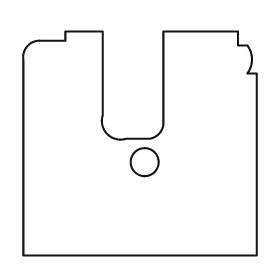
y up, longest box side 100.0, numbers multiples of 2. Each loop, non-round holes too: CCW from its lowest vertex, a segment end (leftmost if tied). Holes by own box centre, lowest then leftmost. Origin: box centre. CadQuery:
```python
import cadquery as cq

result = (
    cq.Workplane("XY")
    .moveTo(-50.0, -48.0)
    .lineTo(50.0, -48.0)
    .lineTo(50.0, 30.0)
    .lineTo(46.0, 30.0)
    .threePointArc((48.0, 36.0), (46.0, 42.0))
    .lineTo(42.0, 42.0)
    .lineTo(42.0, 48.0)
    .lineTo(10.0, 48.0)
    .lineTo(10.0, 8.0)
    .threePointArc((8.0, 4.0), (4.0, 2.0))
    .lineTo(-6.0, 2.0)
    .threePointArc((-14.0, 4.0), (-16.0, 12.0))
    .lineTo(-16.0, 48.0)
    .lineTo(-32.0, 48.0)
    .lineTo(-32.0, 44.0)
    .lineTo(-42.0, 44.0)
    .threePointArc((-48.0, 42.0), (-50.0, 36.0))
    .close()
    .moveTo(2.0, -8.0)
    .circle(6.0)
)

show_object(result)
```